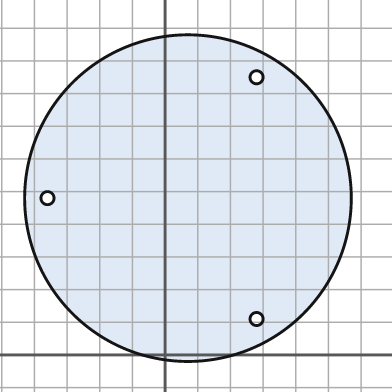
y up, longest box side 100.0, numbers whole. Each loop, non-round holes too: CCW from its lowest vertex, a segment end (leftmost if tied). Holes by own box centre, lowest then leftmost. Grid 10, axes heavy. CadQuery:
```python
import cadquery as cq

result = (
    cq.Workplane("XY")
    .moveTo(7.0, 48.0)
    .circle(50.0)
    .moveTo(28.0, 11.0)
    .circle(2.0)
    .moveTo(-36.0, 48.0)
    .circle(2.0)
    .moveTo(28.0, 85.0)
    .circle(2.0)
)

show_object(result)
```